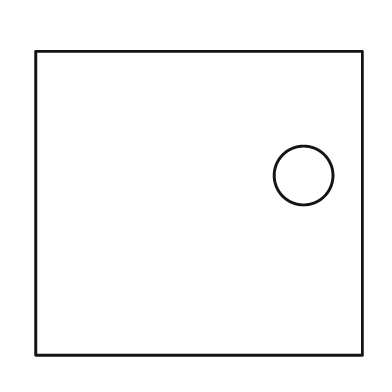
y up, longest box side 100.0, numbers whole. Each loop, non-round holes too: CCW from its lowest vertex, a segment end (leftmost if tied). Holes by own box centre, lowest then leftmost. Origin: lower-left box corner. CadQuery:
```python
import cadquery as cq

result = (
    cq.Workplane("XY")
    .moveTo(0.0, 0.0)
    .lineTo(100.0, 0.0)
    .lineTo(100.0, 93.0)
    .lineTo(0.0, 93.0)
    .close()
    .moveTo(82.0, 55.0)
    .circle(9.0)
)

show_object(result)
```